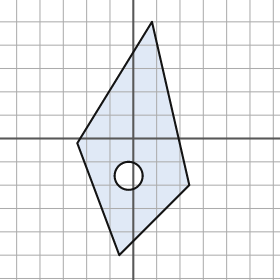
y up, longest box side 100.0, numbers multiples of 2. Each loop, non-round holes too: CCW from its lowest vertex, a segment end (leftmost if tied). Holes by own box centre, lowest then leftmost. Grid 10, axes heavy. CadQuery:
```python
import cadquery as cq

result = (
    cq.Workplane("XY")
    .moveTo(-6.0, -50.0)
    .lineTo(24.0, -20.0)
    .lineTo(8.0, 50.0)
    .lineTo(-24.0, -2.0)
    .close()
    .moveTo(-2.0, -16.0)
    .circle(6.0)
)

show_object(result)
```